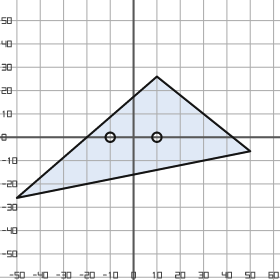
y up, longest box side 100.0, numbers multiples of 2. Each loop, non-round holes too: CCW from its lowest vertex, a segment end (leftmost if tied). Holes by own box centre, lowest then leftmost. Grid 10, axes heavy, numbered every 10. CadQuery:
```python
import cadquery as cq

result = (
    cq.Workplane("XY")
    .moveTo(-50.0, -26.0)
    .lineTo(50.0, -6.0)
    .lineTo(10.0, 26.0)
    .close()
    .moveTo(-10.0, 0.0)
    .circle(2.0)
    .moveTo(10.0, 0.0)
    .circle(2.0)
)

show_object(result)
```